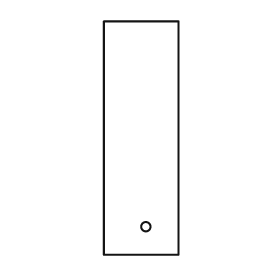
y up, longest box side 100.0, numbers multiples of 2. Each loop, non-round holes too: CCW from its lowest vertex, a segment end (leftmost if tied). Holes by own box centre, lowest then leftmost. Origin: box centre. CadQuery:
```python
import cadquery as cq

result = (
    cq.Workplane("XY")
    .moveTo(-16.0, -50.0)
    .lineTo(16.0, -50.0)
    .lineTo(16.0, 50.0)
    .lineTo(-16.0, 50.0)
    .close()
    .moveTo(2.0, -38.0)
    .circle(2.0)
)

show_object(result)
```